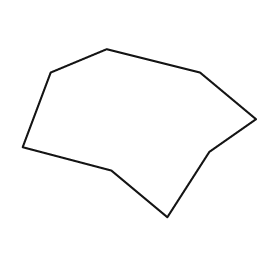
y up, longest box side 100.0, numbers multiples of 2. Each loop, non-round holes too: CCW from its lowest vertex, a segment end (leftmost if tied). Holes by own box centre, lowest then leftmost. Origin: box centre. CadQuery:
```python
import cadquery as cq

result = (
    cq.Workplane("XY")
    .moveTo(12.0, -36.0)
    .lineTo(30.0, -8.0)
    .lineTo(50.0, 6.0)
    .lineTo(26.0, 26.0)
    .lineTo(-14.0, 36.0)
    .lineTo(-38.0, 26.0)
    .lineTo(-50.0, -6.0)
    .lineTo(-12.0, -16.0)
    .close()
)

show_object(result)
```